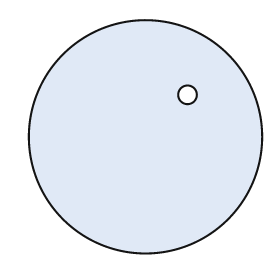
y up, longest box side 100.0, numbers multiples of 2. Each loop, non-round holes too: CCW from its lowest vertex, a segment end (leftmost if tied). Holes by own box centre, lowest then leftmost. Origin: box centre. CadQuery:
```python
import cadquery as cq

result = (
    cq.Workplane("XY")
    .moveTo(0.0, 0.0)
    .circle(50.0)
    .moveTo(18.0, 18.0)
    .circle(4.0)
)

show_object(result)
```